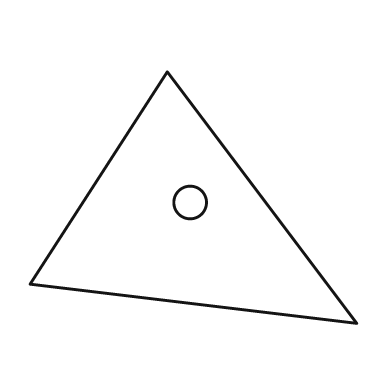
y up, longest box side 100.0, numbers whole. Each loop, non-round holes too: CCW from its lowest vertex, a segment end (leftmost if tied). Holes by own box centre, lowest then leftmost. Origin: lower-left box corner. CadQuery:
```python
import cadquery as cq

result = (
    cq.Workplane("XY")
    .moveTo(100.0, 0.0)
    .lineTo(42.0, 77.0)
    .lineTo(0.0, 12.0)
    .close()
    .moveTo(49.0, 37.0)
    .circle(5.0)
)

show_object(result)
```